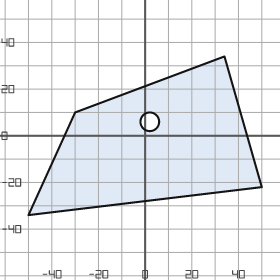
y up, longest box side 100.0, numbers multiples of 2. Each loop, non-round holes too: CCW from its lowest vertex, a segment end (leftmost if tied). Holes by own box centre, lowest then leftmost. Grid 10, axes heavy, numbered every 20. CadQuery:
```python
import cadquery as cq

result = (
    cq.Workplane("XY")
    .moveTo(-50.0, -34.0)
    .lineTo(50.0, -22.0)
    .lineTo(34.0, 34.0)
    .lineTo(-30.0, 10.0)
    .close()
    .moveTo(2.0, 6.0)
    .circle(4.0)
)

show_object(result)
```